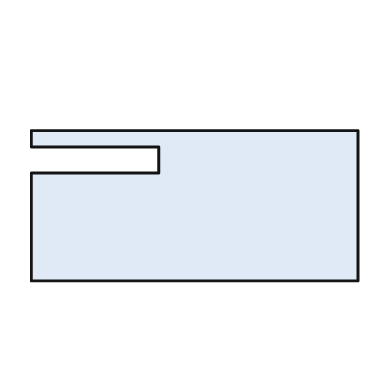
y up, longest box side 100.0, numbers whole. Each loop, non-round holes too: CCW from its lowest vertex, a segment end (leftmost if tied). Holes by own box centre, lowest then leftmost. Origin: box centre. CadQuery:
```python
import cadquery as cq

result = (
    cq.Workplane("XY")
    .moveTo(-50.0, -23.0)
    .lineTo(50.0, -23.0)
    .lineTo(50.0, 23.0)
    .lineTo(-50.0, 23.0)
    .lineTo(-50.0, 18.0)
    .lineTo(-11.0, 18.0)
    .lineTo(-11.0, 10.0)
    .lineTo(-50.0, 10.0)
    .close()
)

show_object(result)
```